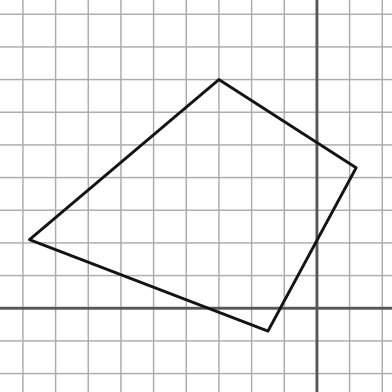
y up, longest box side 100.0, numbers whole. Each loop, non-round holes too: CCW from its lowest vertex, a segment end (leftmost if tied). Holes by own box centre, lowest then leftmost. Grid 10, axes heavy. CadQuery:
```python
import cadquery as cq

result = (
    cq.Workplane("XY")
    .moveTo(-15.0, -7.0)
    .lineTo(12.0, 43.0)
    .lineTo(-30.0, 70.0)
    .lineTo(-88.0, 21.0)
    .close()
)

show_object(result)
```